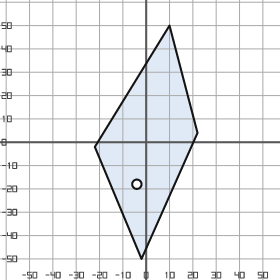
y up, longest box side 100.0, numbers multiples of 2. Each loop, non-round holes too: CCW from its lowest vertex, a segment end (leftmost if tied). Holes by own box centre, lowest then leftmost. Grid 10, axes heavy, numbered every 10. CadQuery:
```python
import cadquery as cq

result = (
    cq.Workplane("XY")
    .moveTo(-2.0, -50.0)
    .lineTo(22.0, 4.0)
    .lineTo(10.0, 50.0)
    .lineTo(-22.0, -2.0)
    .close()
    .moveTo(-4.0, -18.0)
    .circle(2.0)
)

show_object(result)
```